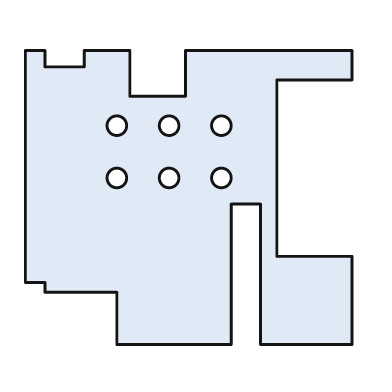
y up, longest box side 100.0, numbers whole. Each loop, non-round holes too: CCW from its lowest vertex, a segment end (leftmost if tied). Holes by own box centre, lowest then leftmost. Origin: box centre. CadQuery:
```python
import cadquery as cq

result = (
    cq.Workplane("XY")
    .moveTo(-22.0, -45.0)
    .lineTo(13.0, -45.0)
    .lineTo(13.0, -2.0)
    .lineTo(22.0, -2.0)
    .lineTo(22.0, -45.0)
    .lineTo(50.0, -45.0)
    .lineTo(50.0, -18.0)
    .lineTo(27.0, -18.0)
    .lineTo(27.0, 36.0)
    .lineTo(50.0, 36.0)
    .lineTo(50.0, 45.0)
    .lineTo(-1.0, 45.0)
    .lineTo(-1.0, 31.0)
    .lineTo(-18.0, 31.0)
    .lineTo(-18.0, 45.0)
    .lineTo(-32.0, 45.0)
    .lineTo(-32.0, 40.0)
    .lineTo(-44.0, 40.0)
    .lineTo(-44.0, 45.0)
    .lineTo(-50.0, 45.0)
    .lineTo(-50.0, -26.0)
    .lineTo(-44.0, -26.0)
    .lineTo(-44.0, -29.0)
    .lineTo(-22.0, -29.0)
    .close()
    .moveTo(-22.0, 6.0)
    .circle(3.0)
    .moveTo(-6.0, 6.0)
    .circle(3.0)
    .moveTo(10.0, 6.0)
    .circle(3.0)
    .moveTo(-22.0, 22.0)
    .circle(3.0)
    .moveTo(-6.0, 22.0)
    .circle(3.0)
    .moveTo(10.0, 22.0)
    .circle(3.0)
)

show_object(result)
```